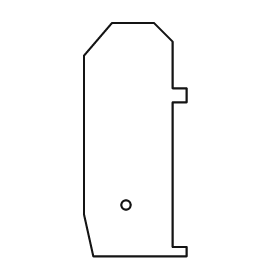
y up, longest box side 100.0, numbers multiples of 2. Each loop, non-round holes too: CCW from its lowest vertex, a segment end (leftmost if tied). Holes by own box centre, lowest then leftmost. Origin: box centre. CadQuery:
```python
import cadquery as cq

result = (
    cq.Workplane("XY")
    .moveTo(-18.0, -50.0)
    .lineTo(22.0, -50.0)
    .lineTo(22.0, -46.0)
    .lineTo(16.0, -46.0)
    .lineTo(16.0, 16.0)
    .lineTo(22.0, 16.0)
    .lineTo(22.0, 22.0)
    .lineTo(16.0, 22.0)
    .lineTo(16.0, 42.0)
    .lineTo(8.0, 50.0)
    .lineTo(-10.0, 50.0)
    .lineTo(-22.0, 36.0)
    .lineTo(-22.0, -32.0)
    .close()
    .moveTo(-4.0, -28.0)
    .circle(2.0)
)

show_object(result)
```